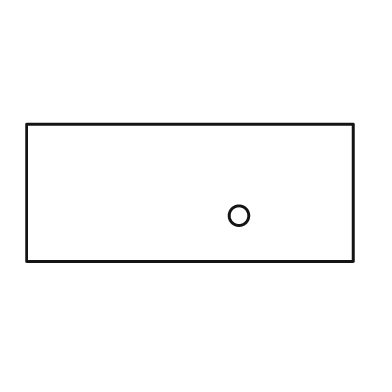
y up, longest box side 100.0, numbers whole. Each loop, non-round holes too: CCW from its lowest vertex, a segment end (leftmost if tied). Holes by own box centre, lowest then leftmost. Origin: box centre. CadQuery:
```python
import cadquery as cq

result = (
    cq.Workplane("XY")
    .moveTo(-50.0, -21.0)
    .lineTo(50.0, -21.0)
    .lineTo(50.0, 21.0)
    .lineTo(-50.0, 21.0)
    .close()
    .moveTo(15.0, -7.0)
    .circle(3.0)
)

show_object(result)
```